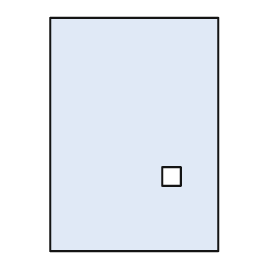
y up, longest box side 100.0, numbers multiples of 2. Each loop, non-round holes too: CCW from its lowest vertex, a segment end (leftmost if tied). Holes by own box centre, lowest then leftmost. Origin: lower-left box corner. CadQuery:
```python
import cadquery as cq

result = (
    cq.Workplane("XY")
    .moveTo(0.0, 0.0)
    .lineTo(72.0, 0.0)
    .lineTo(72.0, 100.0)
    .lineTo(0.0, 100.0)
    .close()
    .moveTo(48.0, 28.0)
    .lineTo(56.0, 28.0)
    .lineTo(56.0, 36.0)
    .lineTo(48.0, 36.0)
    .close()
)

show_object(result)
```